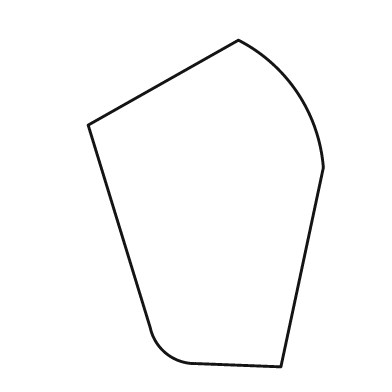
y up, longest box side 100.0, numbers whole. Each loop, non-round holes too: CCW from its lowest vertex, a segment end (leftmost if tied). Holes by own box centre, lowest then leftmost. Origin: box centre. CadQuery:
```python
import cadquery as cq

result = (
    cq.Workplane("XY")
    .moveTo(23.0, -50.0)
    .lineTo(36.0, 11.0)
    .threePointArc((28.0, 34.0), (10.0, 50.0))
    .lineTo(-36.0, 24.0)
    .lineTo(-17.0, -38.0)
    .threePointArc((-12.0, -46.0), (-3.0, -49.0))
    .close()
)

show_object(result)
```